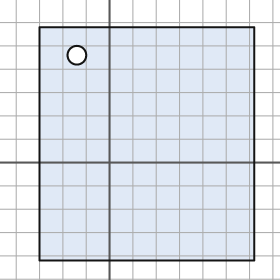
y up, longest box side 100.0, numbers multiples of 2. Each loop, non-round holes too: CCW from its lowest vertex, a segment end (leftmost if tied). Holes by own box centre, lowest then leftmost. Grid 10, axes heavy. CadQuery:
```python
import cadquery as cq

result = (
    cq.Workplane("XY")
    .moveTo(-30.0, -42.0)
    .lineTo(62.0, -42.0)
    .lineTo(62.0, 58.0)
    .lineTo(-30.0, 58.0)
    .close()
    .moveTo(-14.0, 46.0)
    .circle(4.0)
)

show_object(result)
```